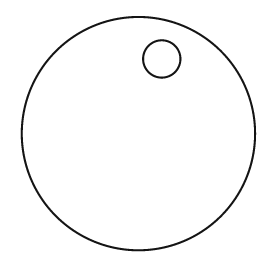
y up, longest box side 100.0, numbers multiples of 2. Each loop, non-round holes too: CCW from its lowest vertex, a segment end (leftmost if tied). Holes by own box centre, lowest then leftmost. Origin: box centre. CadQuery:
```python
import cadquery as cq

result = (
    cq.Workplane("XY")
    .moveTo(0.0, 0.0)
    .circle(50.0)
    .moveTo(10.0, 32.0)
    .circle(8.0)
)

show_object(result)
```